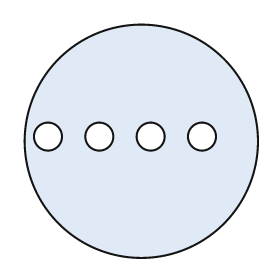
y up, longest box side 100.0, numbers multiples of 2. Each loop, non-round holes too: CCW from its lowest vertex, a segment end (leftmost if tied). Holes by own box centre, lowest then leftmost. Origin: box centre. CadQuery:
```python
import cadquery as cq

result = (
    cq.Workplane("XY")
    .moveTo(0.0, 0.0)
    .circle(50.0)
    .moveTo(-40.0, 2.0)
    .circle(6.0)
    .moveTo(-18.0, 2.0)
    .circle(6.0)
    .moveTo(4.0, 2.0)
    .circle(6.0)
    .moveTo(26.0, 2.0)
    .circle(6.0)
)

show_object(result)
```